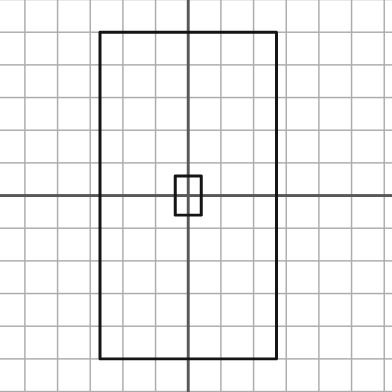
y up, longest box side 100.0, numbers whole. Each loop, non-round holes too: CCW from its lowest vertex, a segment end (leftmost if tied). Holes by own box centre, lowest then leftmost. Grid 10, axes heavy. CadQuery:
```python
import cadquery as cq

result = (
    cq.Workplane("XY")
    .moveTo(-27.0, -50.0)
    .lineTo(27.0, -50.0)
    .lineTo(27.0, 50.0)
    .lineTo(-27.0, 50.0)
    .close()
    .moveTo(-4.0, -6.0)
    .lineTo(4.0, -6.0)
    .lineTo(4.0, 6.0)
    .lineTo(-4.0, 6.0)
    .close()
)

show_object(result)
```